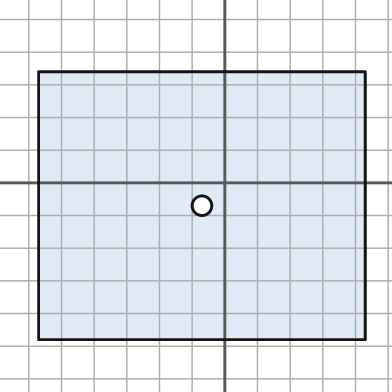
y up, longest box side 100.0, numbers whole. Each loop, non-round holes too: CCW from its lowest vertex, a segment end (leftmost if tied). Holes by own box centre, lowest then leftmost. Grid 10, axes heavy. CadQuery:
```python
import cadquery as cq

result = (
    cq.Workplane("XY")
    .moveTo(-57.0, -48.0)
    .lineTo(43.0, -48.0)
    .lineTo(43.0, 34.0)
    .lineTo(-57.0, 34.0)
    .close()
    .moveTo(-7.0, -7.0)
    .circle(3.0)
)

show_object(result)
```